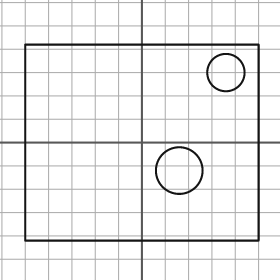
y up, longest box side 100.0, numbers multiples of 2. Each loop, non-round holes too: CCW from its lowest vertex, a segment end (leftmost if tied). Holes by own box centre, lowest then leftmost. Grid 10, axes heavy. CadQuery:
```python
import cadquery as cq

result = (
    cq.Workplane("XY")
    .moveTo(-50.0, -42.0)
    .lineTo(50.0, -42.0)
    .lineTo(50.0, 42.0)
    .lineTo(-50.0, 42.0)
    .close()
    .moveTo(16.0, -12.0)
    .circle(10.0)
    .moveTo(36.0, 30.0)
    .circle(8.0)
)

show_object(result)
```